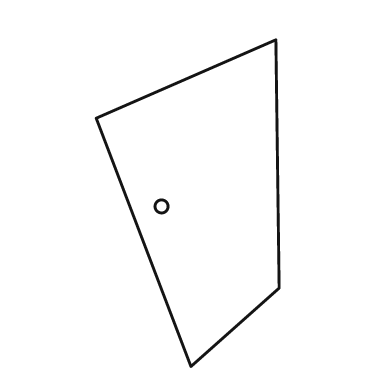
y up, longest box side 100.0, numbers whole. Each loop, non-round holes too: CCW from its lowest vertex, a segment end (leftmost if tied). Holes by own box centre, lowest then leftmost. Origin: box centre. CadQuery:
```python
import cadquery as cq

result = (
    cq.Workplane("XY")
    .moveTo(1.0, -50.0)
    .lineTo(28.0, -26.0)
    .lineTo(27.0, 50.0)
    .lineTo(-28.0, 26.0)
    .close()
    .moveTo(-8.0, -1.0)
    .circle(2.0)
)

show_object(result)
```